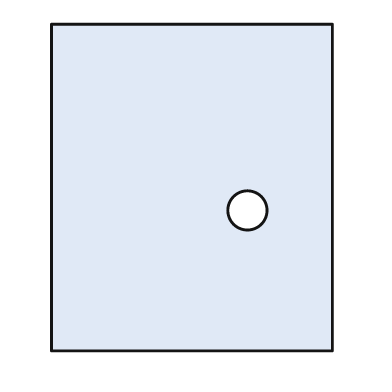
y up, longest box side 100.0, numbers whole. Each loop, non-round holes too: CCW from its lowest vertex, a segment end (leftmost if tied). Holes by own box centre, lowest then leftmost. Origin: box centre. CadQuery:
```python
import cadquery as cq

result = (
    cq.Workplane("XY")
    .moveTo(-43.0, -50.0)
    .lineTo(43.0, -50.0)
    .lineTo(43.0, 50.0)
    .lineTo(-43.0, 50.0)
    .close()
    .moveTo(17.0, -7.0)
    .circle(6.0)
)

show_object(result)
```